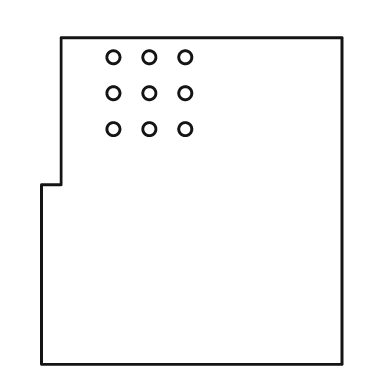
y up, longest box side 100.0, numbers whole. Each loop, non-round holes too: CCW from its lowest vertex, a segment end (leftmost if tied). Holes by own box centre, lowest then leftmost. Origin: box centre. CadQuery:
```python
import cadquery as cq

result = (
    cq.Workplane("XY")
    .moveTo(-46.0, -50.0)
    .lineTo(46.0, -50.0)
    .lineTo(46.0, 50.0)
    .lineTo(-40.0, 50.0)
    .lineTo(-40.0, 5.0)
    .lineTo(-46.0, 5.0)
    .close()
    .moveTo(-24.0, 22.0)
    .circle(2.0)
    .moveTo(-13.0, 22.0)
    .circle(2.0)
    .moveTo(-2.0, 22.0)
    .circle(2.0)
    .moveTo(-24.0, 33.0)
    .circle(2.0)
    .moveTo(-13.0, 33.0)
    .circle(2.0)
    .moveTo(-2.0, 33.0)
    .circle(2.0)
    .moveTo(-24.0, 44.0)
    .circle(2.0)
    .moveTo(-13.0, 44.0)
    .circle(2.0)
    .moveTo(-2.0, 44.0)
    .circle(2.0)
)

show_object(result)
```